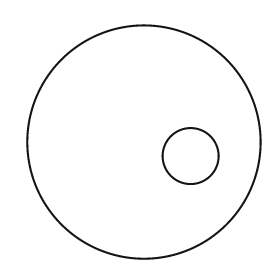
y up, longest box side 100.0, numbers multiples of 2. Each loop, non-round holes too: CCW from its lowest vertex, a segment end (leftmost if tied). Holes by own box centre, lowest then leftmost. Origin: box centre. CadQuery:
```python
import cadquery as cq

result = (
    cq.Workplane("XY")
    .moveTo(0.0, 0.0)
    .circle(50.0)
    .moveTo(20.0, -6.0)
    .circle(12.0)
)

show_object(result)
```